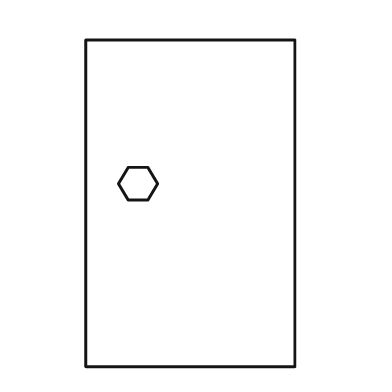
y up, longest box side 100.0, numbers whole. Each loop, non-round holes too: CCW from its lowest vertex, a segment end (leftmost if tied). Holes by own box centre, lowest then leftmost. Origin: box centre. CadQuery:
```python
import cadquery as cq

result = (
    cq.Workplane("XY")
    .moveTo(-32.0, -50.0)
    .lineTo(32.0, -50.0)
    .lineTo(32.0, 50.0)
    .lineTo(-32.0, 50.0)
    .close()
    .moveTo(-19.0, 1.0)
    .lineTo(-13.0, 1.0)
    .lineTo(-10.0, 6.0)
    .lineTo(-13.0, 11.0)
    .lineTo(-19.0, 11.0)
    .lineTo(-22.0, 6.0)
    .close()
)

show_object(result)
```